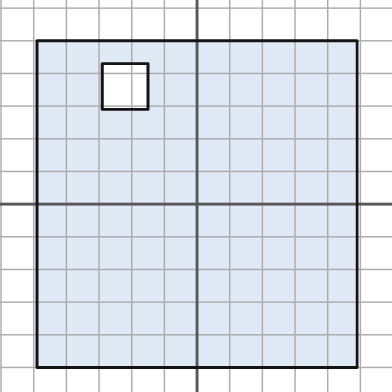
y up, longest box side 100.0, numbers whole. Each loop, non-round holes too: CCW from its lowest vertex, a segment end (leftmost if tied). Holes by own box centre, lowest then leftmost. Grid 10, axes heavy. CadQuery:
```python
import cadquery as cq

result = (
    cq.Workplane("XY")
    .moveTo(-49.0, -50.0)
    .lineTo(49.0, -50.0)
    .lineTo(49.0, 50.0)
    .lineTo(-49.0, 50.0)
    .close()
    .moveTo(-29.0, 29.0)
    .lineTo(-15.0, 29.0)
    .lineTo(-15.0, 43.0)
    .lineTo(-29.0, 43.0)
    .close()
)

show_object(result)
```